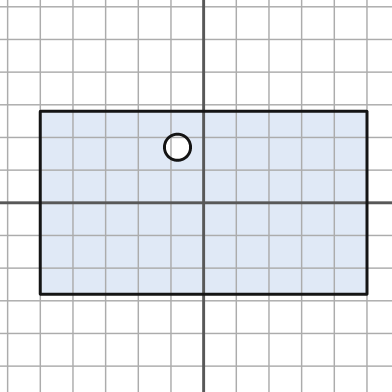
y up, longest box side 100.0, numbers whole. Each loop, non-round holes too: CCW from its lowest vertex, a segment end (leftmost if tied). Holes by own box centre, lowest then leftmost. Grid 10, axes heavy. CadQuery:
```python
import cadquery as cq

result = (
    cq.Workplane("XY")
    .moveTo(-50.0, -28.0)
    .lineTo(50.0, -28.0)
    .lineTo(50.0, 28.0)
    .lineTo(-50.0, 28.0)
    .close()
    .moveTo(-8.0, 17.0)
    .circle(4.0)
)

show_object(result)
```